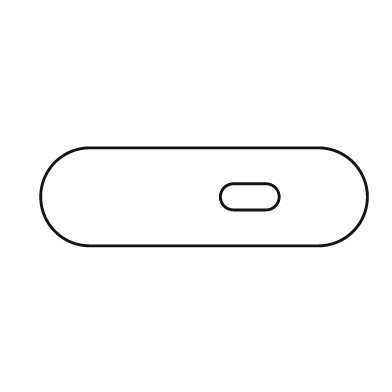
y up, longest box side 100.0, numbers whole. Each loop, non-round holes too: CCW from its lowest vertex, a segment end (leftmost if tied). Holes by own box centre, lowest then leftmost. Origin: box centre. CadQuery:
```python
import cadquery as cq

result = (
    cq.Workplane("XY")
    .moveTo(-35.0, -15.0)
    .lineTo(35.0, -15.0)
    .threePointArc((50.0, 0.0), (35.0, 15.0))
    .lineTo(-35.0, 15.0)
    .threePointArc((-50.0, 0.0), (-35.0, -15.0))
    .close()
    .moveTo(9.0, -4.0)
    .lineTo(19.0, -4.0)
    .threePointArc((23.0, 0.0), (19.0, 4.0))
    .lineTo(9.0, 4.0)
    .threePointArc((5.0, 0.0), (9.0, -4.0))
    .close()
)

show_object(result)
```